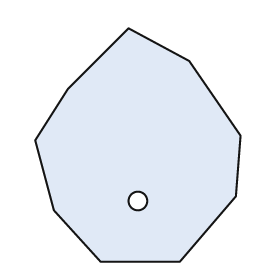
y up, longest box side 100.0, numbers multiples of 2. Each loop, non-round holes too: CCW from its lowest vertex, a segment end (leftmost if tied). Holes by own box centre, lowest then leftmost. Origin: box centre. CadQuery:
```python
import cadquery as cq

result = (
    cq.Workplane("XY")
    .moveTo(-16.0, -50.0)
    .lineTo(18.0, -50.0)
    .lineTo(42.0, -22.0)
    .lineTo(44.0, 4.0)
    .lineTo(22.0, 36.0)
    .lineTo(-4.0, 50.0)
    .lineTo(-30.0, 24.0)
    .lineTo(-44.0, 2.0)
    .lineTo(-36.0, -28.0)
    .close()
    .moveTo(0.0, -24.0)
    .circle(4.0)
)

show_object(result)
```